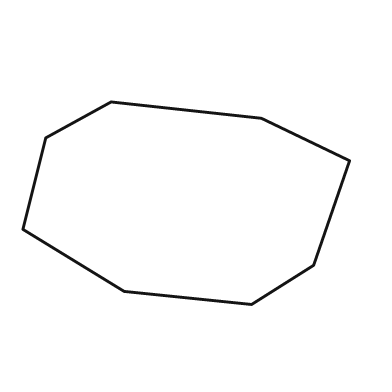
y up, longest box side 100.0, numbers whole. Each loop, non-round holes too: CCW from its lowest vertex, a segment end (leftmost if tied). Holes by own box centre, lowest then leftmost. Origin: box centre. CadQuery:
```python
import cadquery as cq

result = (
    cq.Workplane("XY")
    .moveTo(20.0, -31.0)
    .lineTo(39.0, -19.0)
    .lineTo(50.0, 13.0)
    .lineTo(23.0, 26.0)
    .lineTo(-23.0, 31.0)
    .lineTo(-43.0, 20.0)
    .lineTo(-50.0, -8.0)
    .lineTo(-19.0, -27.0)
    .close()
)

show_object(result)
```